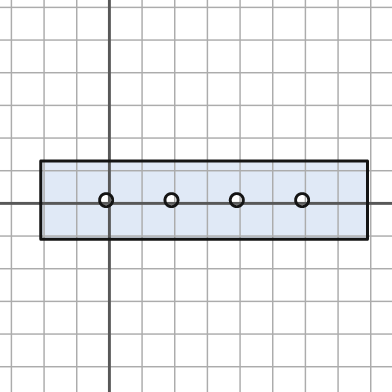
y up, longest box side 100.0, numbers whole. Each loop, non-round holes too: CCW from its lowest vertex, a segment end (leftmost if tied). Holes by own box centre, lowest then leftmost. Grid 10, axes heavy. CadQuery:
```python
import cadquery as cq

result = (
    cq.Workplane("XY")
    .moveTo(-21.0, -11.0)
    .lineTo(79.0, -11.0)
    .lineTo(79.0, 13.0)
    .lineTo(-21.0, 13.0)
    .close()
    .moveTo(-1.0, 1.0)
    .circle(2.0)
    .moveTo(19.0, 1.0)
    .circle(2.0)
    .moveTo(39.0, 1.0)
    .circle(2.0)
    .moveTo(59.0, 1.0)
    .circle(2.0)
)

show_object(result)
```